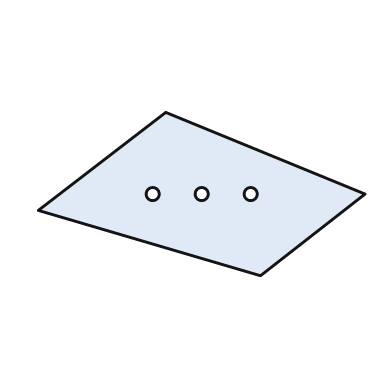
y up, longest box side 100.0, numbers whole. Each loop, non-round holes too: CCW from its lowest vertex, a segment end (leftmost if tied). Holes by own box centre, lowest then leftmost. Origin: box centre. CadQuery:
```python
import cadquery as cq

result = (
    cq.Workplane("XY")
    .moveTo(18.0, -25.0)
    .lineTo(50.0, 0.0)
    .lineTo(-11.0, 25.0)
    .lineTo(-50.0, -5.0)
    .close()
    .moveTo(-15.0, 0.0)
    .circle(2.0)
    .moveTo(0.0, 0.0)
    .circle(2.0)
    .moveTo(15.0, 0.0)
    .circle(2.0)
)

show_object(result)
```